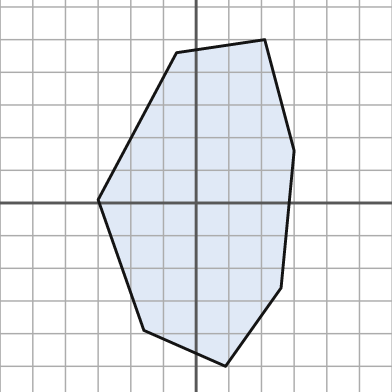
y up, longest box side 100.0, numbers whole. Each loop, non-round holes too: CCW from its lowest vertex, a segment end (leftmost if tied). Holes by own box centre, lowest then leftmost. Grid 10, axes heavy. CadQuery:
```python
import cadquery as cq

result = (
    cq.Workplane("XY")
    .moveTo(9.0, -50.0)
    .lineTo(26.0, -26.0)
    .lineTo(30.0, 16.0)
    .lineTo(21.0, 50.0)
    .lineTo(-6.0, 46.0)
    .lineTo(-30.0, 1.0)
    .lineTo(-16.0, -39.0)
    .close()
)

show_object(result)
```